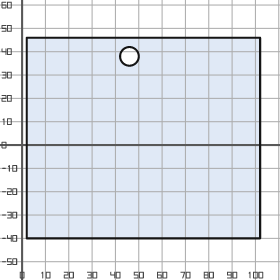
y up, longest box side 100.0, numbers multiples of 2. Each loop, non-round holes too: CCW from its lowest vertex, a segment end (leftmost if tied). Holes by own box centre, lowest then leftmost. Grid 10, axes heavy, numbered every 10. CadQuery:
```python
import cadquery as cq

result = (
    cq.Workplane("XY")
    .moveTo(2.0, -40.0)
    .lineTo(102.0, -40.0)
    .lineTo(102.0, 46.0)
    .lineTo(2.0, 46.0)
    .close()
    .moveTo(46.0, 38.0)
    .circle(4.0)
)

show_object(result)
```